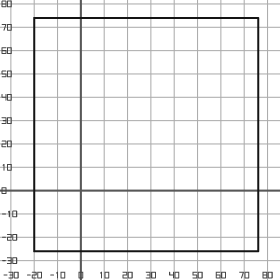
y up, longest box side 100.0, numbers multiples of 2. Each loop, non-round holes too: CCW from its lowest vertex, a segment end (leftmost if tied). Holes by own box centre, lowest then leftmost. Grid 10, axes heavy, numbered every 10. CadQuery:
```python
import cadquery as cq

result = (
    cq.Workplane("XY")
    .moveTo(-20.0, -26.0)
    .lineTo(76.0, -26.0)
    .lineTo(76.0, 74.0)
    .lineTo(-20.0, 74.0)
    .close()
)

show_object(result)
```